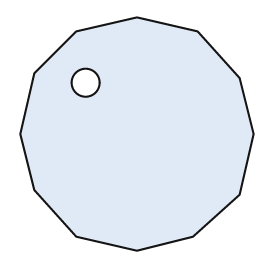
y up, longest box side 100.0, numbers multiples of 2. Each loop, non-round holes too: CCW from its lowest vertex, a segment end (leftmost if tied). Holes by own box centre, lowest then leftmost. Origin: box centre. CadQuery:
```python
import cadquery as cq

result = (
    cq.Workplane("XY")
    .moveTo(0.0, -50.0)
    .lineTo(24.0, -44.0)
    .lineTo(44.0, -26.0)
    .lineTo(50.0, 0.0)
    .lineTo(44.0, 24.0)
    .lineTo(26.0, 44.0)
    .lineTo(0.0, 50.0)
    .lineTo(-26.0, 44.0)
    .lineTo(-44.0, 26.0)
    .lineTo(-50.0, 0.0)
    .lineTo(-44.0, -24.0)
    .lineTo(-26.0, -44.0)
    .close()
    .moveTo(-22.0, 22.0)
    .circle(6.0)
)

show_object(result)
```